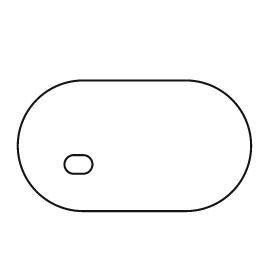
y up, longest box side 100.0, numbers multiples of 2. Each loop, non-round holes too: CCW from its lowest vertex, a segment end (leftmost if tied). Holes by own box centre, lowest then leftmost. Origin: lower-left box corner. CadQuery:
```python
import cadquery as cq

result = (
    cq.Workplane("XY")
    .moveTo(28.0, 0.0)
    .lineTo(72.0, 0.0)
    .threePointArc((100.0, 28.0), (72.0, 56.0))
    .lineTo(28.0, 56.0)
    .threePointArc((0.0, 28.0), (28.0, 0.0))
    .close()
    .moveTo(24.0, 16.0)
    .lineTo(28.0, 16.0)
    .threePointArc((32.0, 20.0), (28.0, 24.0))
    .lineTo(24.0, 24.0)
    .threePointArc((20.0, 20.0), (24.0, 16.0))
    .close()
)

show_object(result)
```